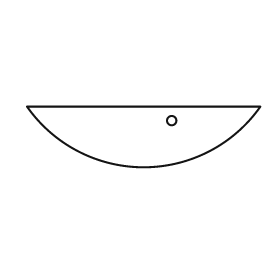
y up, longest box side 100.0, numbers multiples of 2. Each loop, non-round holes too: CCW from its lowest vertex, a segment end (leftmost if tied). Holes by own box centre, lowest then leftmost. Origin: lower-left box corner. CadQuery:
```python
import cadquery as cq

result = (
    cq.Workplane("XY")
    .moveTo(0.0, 26.0)
    .threePointArc((50.0, 0.0), (100.0, 26.0))
    .close()
    .moveTo(62.0, 20.0)
    .circle(2.0)
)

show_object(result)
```